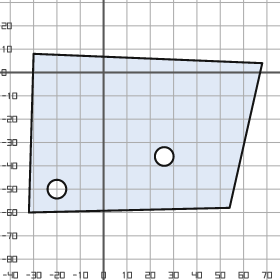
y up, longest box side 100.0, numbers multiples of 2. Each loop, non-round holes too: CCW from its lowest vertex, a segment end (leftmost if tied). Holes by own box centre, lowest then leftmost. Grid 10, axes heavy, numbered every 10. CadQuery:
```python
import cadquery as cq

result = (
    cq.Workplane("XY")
    .moveTo(-32.0, -60.0)
    .lineTo(54.0, -58.0)
    .lineTo(68.0, 4.0)
    .lineTo(-30.0, 8.0)
    .close()
    .moveTo(-20.0, -50.0)
    .circle(4.0)
    .moveTo(26.0, -36.0)
    .circle(4.0)
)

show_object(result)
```